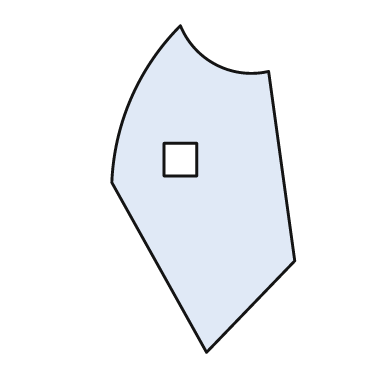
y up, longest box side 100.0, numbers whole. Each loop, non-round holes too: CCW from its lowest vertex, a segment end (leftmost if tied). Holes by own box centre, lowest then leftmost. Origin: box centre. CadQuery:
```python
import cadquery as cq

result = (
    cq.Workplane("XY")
    .moveTo(1.0, -50.0)
    .lineTo(28.0, -22.0)
    .lineTo(20.0, 36.0)
    .threePointArc((4.0, 38.0), (-7.0, 50.0))
    .threePointArc((-22.0, 28.0), (-28.0, 2.0))
    .close()
    .moveTo(-12.0, 4.0)
    .lineTo(-2.0, 4.0)
    .lineTo(-2.0, 14.0)
    .lineTo(-12.0, 14.0)
    .close()
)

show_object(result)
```